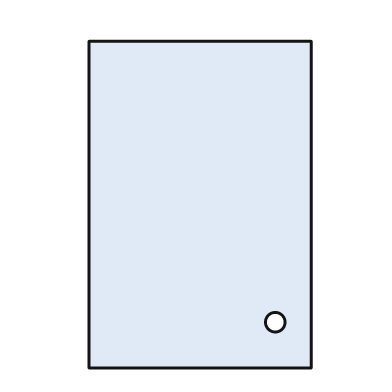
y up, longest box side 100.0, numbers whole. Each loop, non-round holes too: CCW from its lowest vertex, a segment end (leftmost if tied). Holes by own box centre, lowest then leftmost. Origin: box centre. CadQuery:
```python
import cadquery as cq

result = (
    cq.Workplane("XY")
    .moveTo(-34.0, -50.0)
    .lineTo(34.0, -50.0)
    .lineTo(34.0, 50.0)
    .lineTo(-34.0, 50.0)
    .close()
    .moveTo(23.0, -36.0)
    .circle(3.0)
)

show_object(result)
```